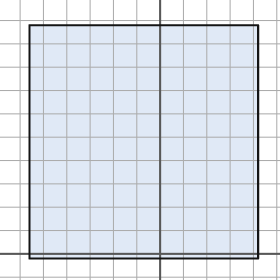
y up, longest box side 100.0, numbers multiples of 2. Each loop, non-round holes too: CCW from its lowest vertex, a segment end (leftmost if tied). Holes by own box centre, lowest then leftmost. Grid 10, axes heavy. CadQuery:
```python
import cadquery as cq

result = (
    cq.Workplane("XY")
    .moveTo(-56.0, -2.0)
    .lineTo(42.0, -2.0)
    .lineTo(42.0, 98.0)
    .lineTo(-56.0, 98.0)
    .close()
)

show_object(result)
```